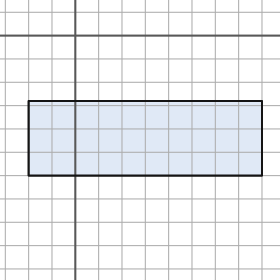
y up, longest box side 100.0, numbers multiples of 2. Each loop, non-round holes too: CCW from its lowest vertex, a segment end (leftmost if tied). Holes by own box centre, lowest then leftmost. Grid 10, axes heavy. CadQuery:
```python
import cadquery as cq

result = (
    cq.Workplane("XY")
    .moveTo(-20.0, -60.0)
    .lineTo(80.0, -60.0)
    .lineTo(80.0, -28.0)
    .lineTo(-20.0, -28.0)
    .close()
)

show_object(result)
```